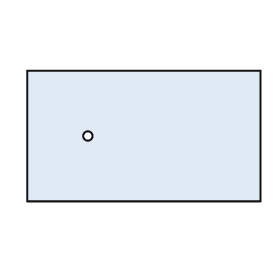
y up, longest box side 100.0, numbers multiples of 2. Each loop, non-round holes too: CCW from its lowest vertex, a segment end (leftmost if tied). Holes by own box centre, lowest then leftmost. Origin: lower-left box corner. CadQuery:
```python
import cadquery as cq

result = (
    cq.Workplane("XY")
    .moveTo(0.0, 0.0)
    .lineTo(100.0, 0.0)
    .lineTo(100.0, 56.0)
    .lineTo(0.0, 56.0)
    .close()
    .moveTo(26.0, 28.0)
    .circle(2.0)
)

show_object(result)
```